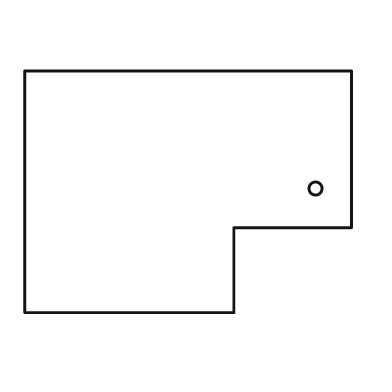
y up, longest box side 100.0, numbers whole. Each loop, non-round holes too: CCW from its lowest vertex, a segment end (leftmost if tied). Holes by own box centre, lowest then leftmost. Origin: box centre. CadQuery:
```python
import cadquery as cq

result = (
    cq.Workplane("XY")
    .moveTo(-50.0, -37.0)
    .lineTo(14.0, -37.0)
    .lineTo(14.0, -11.0)
    .lineTo(50.0, -11.0)
    .lineTo(50.0, 37.0)
    .lineTo(-50.0, 37.0)
    .close()
    .moveTo(39.0, 1.0)
    .circle(2.0)
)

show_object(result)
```